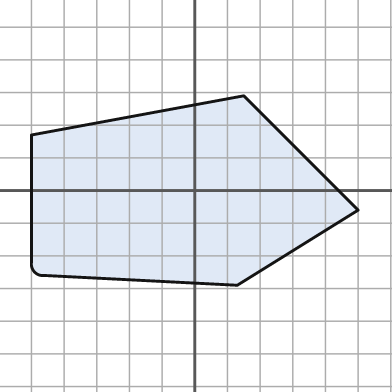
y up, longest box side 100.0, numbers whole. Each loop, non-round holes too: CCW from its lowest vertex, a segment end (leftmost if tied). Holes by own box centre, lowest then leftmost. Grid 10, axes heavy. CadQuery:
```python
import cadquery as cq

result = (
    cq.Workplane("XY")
    .moveTo(13.0, -29.0)
    .lineTo(50.0, -6.0)
    .lineTo(15.0, 29.0)
    .lineTo(-50.0, 17.0)
    .lineTo(-50.0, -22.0)
    .threePointArc((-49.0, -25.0), (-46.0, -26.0))
    .close()
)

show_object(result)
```